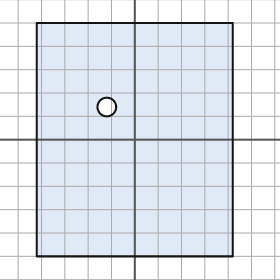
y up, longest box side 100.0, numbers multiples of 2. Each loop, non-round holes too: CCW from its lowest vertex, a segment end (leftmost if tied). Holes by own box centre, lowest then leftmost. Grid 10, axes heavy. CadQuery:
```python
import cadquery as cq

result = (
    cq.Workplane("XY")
    .moveTo(-42.0, -50.0)
    .lineTo(42.0, -50.0)
    .lineTo(42.0, 50.0)
    .lineTo(-42.0, 50.0)
    .close()
    .moveTo(-12.0, 14.0)
    .circle(4.0)
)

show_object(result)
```